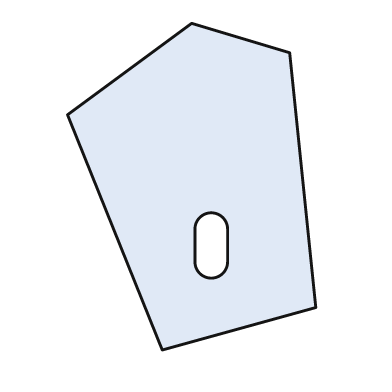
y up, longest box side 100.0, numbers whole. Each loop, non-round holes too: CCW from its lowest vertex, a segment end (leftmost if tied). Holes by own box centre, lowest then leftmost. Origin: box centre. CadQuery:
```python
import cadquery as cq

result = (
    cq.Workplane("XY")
    .moveTo(-9.0, -50.0)
    .lineTo(38.0, -37.0)
    .lineTo(30.0, 41.0)
    .lineTo(0.0, 50.0)
    .lineTo(-38.0, 22.0)
    .close()
    .moveTo(1.0, -23.0)
    .threePointArc((6.0, -28.0), (11.0, -23.0))
    .lineTo(11.0, -13.0)
    .threePointArc((6.0, -8.0), (1.0, -13.0))
    .close()
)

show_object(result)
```